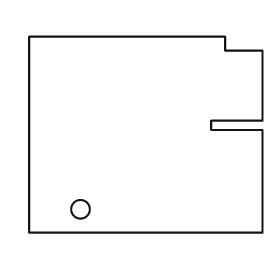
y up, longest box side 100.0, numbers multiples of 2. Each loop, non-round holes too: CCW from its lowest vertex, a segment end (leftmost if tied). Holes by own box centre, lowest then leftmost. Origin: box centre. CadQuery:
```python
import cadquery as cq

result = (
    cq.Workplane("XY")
    .moveTo(-50.0, -42.0)
    .lineTo(50.0, -42.0)
    .lineTo(50.0, 2.0)
    .lineTo(28.0, 2.0)
    .lineTo(28.0, 6.0)
    .lineTo(50.0, 6.0)
    .lineTo(50.0, 36.0)
    .lineTo(34.0, 36.0)
    .lineTo(34.0, 42.0)
    .lineTo(-50.0, 42.0)
    .close()
    .moveTo(-28.0, -32.0)
    .circle(4.0)
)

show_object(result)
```